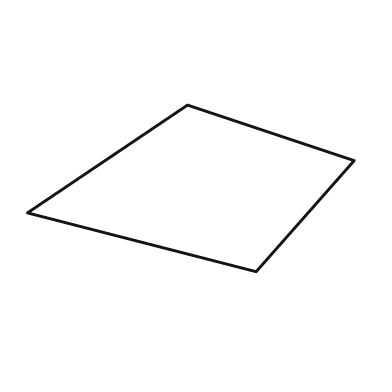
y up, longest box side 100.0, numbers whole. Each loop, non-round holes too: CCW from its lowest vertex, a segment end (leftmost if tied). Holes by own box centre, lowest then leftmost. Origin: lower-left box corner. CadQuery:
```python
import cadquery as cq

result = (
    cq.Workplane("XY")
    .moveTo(70.0, 0.0)
    .lineTo(100.0, 34.0)
    .lineTo(49.0, 51.0)
    .lineTo(0.0, 18.0)
    .close()
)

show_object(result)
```